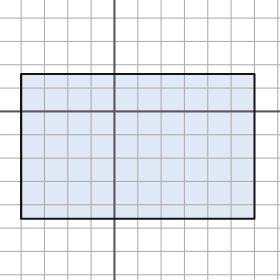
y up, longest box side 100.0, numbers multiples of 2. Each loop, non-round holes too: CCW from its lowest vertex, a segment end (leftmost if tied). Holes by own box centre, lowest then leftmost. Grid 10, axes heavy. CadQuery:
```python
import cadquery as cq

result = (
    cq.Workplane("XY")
    .moveTo(-40.0, -46.0)
    .lineTo(60.0, -46.0)
    .lineTo(60.0, 16.0)
    .lineTo(-40.0, 16.0)
    .close()
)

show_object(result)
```